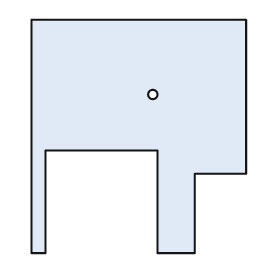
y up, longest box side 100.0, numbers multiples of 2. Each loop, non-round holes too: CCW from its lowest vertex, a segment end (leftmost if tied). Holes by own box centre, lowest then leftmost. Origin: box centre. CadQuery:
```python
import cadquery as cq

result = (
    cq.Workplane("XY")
    .moveTo(-46.0, -50.0)
    .lineTo(-40.0, -50.0)
    .lineTo(-40.0, -6.0)
    .lineTo(8.0, -6.0)
    .lineTo(8.0, -50.0)
    .lineTo(24.0, -50.0)
    .lineTo(24.0, -16.0)
    .lineTo(46.0, -16.0)
    .lineTo(46.0, 50.0)
    .lineTo(-46.0, 50.0)
    .close()
    .moveTo(6.0, 18.0)
    .circle(2.0)
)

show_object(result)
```